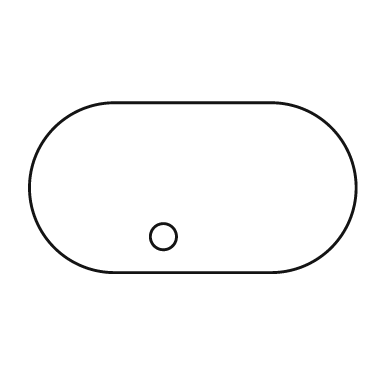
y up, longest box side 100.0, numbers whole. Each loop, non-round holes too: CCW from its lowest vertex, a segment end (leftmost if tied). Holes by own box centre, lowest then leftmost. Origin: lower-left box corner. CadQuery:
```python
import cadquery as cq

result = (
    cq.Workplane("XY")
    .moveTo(26.0, 0.0)
    .lineTo(74.0, 0.0)
    .threePointArc((100.0, 26.0), (74.0, 52.0))
    .lineTo(26.0, 52.0)
    .threePointArc((0.0, 26.0), (26.0, 0.0))
    .close()
    .moveTo(41.0, 11.0)
    .circle(4.0)
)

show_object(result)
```